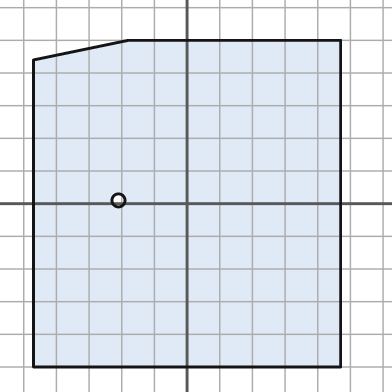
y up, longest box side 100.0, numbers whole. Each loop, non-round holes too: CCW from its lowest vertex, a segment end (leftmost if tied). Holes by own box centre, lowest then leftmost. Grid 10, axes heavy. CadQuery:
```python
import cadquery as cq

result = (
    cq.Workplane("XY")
    .moveTo(-47.0, -50.0)
    .lineTo(47.0, -50.0)
    .lineTo(47.0, 50.0)
    .lineTo(-18.0, 50.0)
    .lineTo(-47.0, 44.0)
    .close()
    .moveTo(-21.0, 1.0)
    .circle(2.0)
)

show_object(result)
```